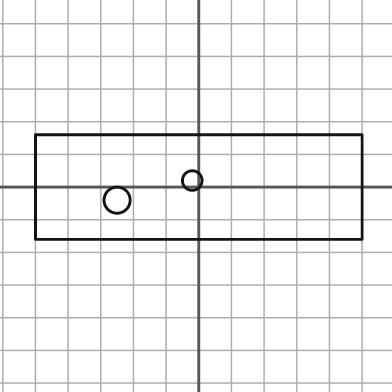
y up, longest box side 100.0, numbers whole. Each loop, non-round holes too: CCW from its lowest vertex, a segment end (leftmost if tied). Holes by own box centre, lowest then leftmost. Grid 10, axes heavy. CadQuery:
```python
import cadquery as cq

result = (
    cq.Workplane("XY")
    .moveTo(-50.0, -16.0)
    .lineTo(50.0, -16.0)
    .lineTo(50.0, 16.0)
    .lineTo(-50.0, 16.0)
    .close()
    .moveTo(-25.0, -4.0)
    .circle(4.0)
    .moveTo(-2.0, 2.0)
    .circle(3.0)
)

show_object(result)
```